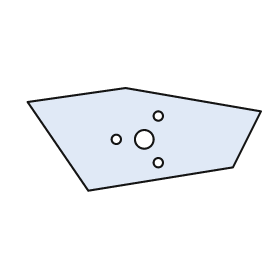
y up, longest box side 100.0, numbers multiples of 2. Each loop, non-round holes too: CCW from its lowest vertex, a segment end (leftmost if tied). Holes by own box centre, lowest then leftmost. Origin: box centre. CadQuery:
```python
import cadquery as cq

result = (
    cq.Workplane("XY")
    .moveTo(-24.0, -22.0)
    .lineTo(38.0, -12.0)
    .lineTo(50.0, 12.0)
    .lineTo(-8.0, 22.0)
    .lineTo(-50.0, 16.0)
    .close()
    .moveTo(6.0, -10.0)
    .circle(2.0)
    .moveTo(-12.0, 0.0)
    .circle(2.0)
    .moveTo(0.0, 0.0)
    .circle(4.0)
    .moveTo(6.0, 10.0)
    .circle(2.0)
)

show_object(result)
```